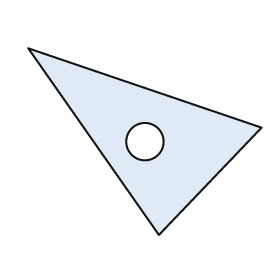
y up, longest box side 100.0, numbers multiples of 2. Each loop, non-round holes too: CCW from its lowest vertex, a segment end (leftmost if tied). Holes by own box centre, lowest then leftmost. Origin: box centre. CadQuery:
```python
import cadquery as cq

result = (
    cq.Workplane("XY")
    .moveTo(6.0, -40.0)
    .lineTo(50.0, 6.0)
    .lineTo(-50.0, 40.0)
    .close()
    .moveTo(0.0, 0.0)
    .circle(8.0)
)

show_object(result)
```